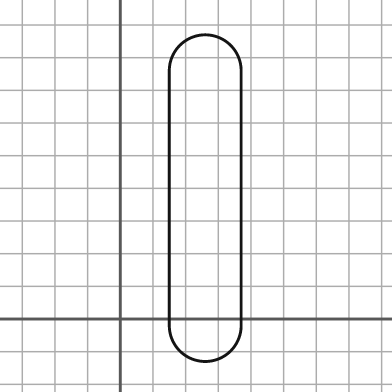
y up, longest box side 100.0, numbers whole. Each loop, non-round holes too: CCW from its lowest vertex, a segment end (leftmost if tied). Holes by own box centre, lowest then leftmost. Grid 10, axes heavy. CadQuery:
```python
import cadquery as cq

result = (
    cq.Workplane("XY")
    .moveTo(15.0, -2.0)
    .threePointArc((26.0, -13.0), (37.0, -2.0))
    .lineTo(37.0, 76.0)
    .threePointArc((26.0, 87.0), (15.0, 76.0))
    .close()
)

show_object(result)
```